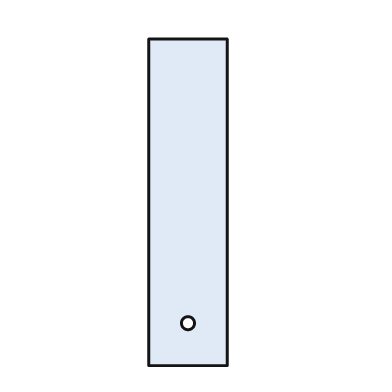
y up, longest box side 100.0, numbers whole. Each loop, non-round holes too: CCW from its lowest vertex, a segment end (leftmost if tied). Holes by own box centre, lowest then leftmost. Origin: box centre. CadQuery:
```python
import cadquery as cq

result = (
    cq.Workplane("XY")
    .moveTo(-12.0, -50.0)
    .lineTo(12.0, -50.0)
    .lineTo(12.0, 50.0)
    .lineTo(-12.0, 50.0)
    .close()
    .moveTo(0.0, -37.0)
    .circle(2.0)
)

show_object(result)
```